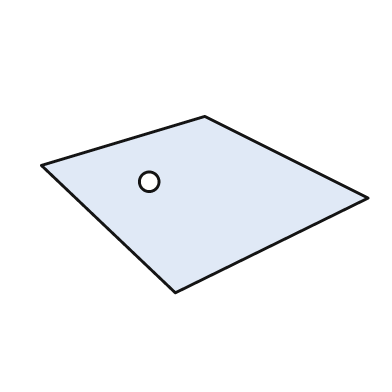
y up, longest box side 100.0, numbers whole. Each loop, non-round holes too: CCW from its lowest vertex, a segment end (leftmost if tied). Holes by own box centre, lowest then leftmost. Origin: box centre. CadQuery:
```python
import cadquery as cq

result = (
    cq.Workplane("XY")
    .moveTo(-9.0, -27.0)
    .lineTo(50.0, 2.0)
    .lineTo(0.0, 27.0)
    .lineTo(-50.0, 12.0)
    .close()
    .moveTo(-17.0, 7.0)
    .circle(3.0)
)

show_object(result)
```